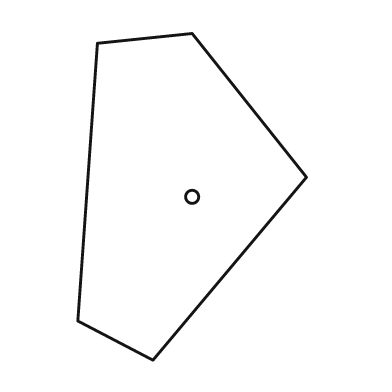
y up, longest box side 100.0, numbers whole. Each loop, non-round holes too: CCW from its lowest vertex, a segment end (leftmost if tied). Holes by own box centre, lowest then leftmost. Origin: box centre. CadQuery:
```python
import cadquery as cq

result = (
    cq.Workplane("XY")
    .moveTo(-12.0, -50.0)
    .lineTo(35.0, 6.0)
    .lineTo(0.0, 50.0)
    .lineTo(-29.0, 47.0)
    .lineTo(-35.0, -38.0)
    .close()
    .moveTo(0.0, 0.0)
    .circle(2.0)
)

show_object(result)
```